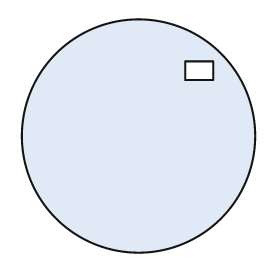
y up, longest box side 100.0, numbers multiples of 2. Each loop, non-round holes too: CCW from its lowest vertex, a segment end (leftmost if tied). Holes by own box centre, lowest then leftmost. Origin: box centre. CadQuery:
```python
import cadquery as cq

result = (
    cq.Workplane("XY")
    .moveTo(0.0, 0.0)
    .circle(50.0)
    .moveTo(20.0, 24.0)
    .lineTo(32.0, 24.0)
    .lineTo(32.0, 32.0)
    .lineTo(20.0, 32.0)
    .close()
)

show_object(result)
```